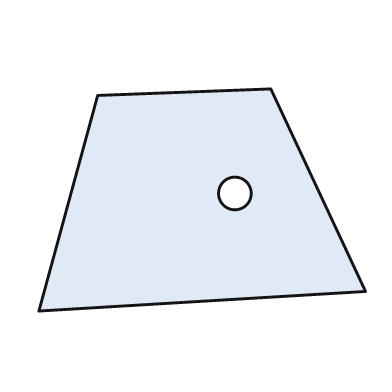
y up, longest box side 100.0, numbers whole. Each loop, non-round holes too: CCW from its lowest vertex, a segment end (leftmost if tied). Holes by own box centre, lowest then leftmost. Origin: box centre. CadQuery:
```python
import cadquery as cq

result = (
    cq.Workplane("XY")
    .moveTo(-50.0, -34.0)
    .lineTo(50.0, -28.0)
    .lineTo(21.0, 34.0)
    .lineTo(-32.0, 32.0)
    .close()
    .moveTo(10.0, 2.0)
    .circle(5.0)
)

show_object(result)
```